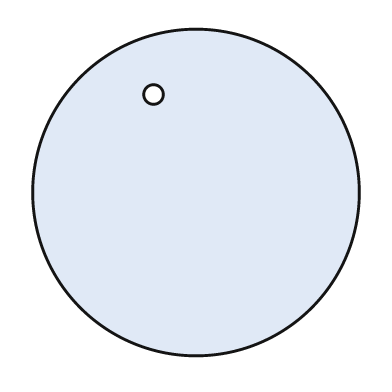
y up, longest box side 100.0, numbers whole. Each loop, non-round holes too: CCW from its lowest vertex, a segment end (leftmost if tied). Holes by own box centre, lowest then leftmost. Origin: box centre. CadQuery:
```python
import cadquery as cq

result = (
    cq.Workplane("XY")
    .moveTo(0.0, 0.0)
    .circle(50.0)
    .moveTo(-13.0, 30.0)
    .circle(3.0)
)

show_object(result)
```